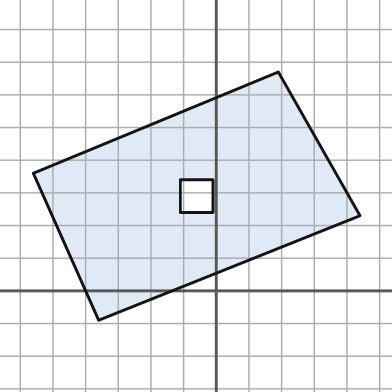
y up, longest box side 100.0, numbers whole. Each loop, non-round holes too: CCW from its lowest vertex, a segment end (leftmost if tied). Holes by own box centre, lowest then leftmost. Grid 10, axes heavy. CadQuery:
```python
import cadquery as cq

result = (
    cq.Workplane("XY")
    .moveTo(-36.0, -9.0)
    .lineTo(44.0, 23.0)
    .lineTo(19.0, 67.0)
    .lineTo(-56.0, 36.0)
    .close()
    .moveTo(-11.0, 24.0)
    .lineTo(-1.0, 24.0)
    .lineTo(-1.0, 34.0)
    .lineTo(-11.0, 34.0)
    .close()
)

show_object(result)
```